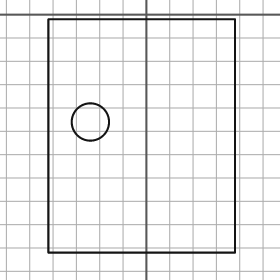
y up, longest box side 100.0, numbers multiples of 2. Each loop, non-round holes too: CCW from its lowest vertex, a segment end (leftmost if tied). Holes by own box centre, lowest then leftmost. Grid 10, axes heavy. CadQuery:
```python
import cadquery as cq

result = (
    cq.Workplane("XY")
    .moveTo(-42.0, -102.0)
    .lineTo(38.0, -102.0)
    .lineTo(38.0, -2.0)
    .lineTo(-42.0, -2.0)
    .close()
    .moveTo(-24.0, -46.0)
    .circle(8.0)
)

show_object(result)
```